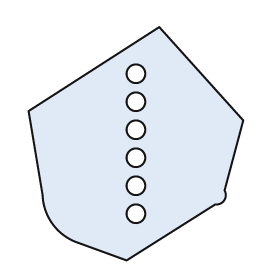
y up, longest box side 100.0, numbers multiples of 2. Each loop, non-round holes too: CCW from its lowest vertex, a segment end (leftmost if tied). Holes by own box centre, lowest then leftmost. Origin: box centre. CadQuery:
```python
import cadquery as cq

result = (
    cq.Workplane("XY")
    .moveTo(-4.0, -50.0)
    .lineTo(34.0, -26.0)
    .threePointArc((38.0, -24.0), (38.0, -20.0))
    .lineTo(46.0, 10.0)
    .lineTo(10.0, 50.0)
    .lineTo(-46.0, 14.0)
    .lineTo(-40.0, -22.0)
    .threePointArc((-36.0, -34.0), (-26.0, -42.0))
    .close()
    .moveTo(0.0, -30.0)
    .circle(4.0)
    .moveTo(0.0, -18.0)
    .circle(4.0)
    .moveTo(0.0, -6.0)
    .circle(4.0)
    .moveTo(0.0, 6.0)
    .circle(4.0)
    .moveTo(0.0, 18.0)
    .circle(4.0)
    .moveTo(0.0, 30.0)
    .circle(4.0)
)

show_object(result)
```